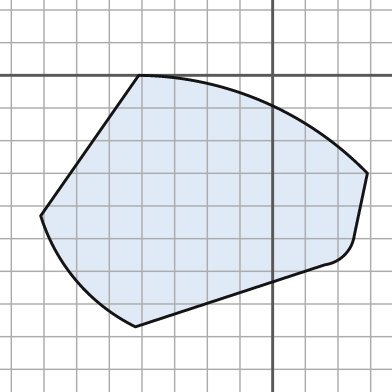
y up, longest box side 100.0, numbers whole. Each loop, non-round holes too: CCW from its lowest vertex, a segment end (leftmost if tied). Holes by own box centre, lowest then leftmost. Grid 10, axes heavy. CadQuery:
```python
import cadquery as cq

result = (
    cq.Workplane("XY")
    .moveTo(-42.0, -77.0)
    .lineTo(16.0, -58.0)
    .threePointArc((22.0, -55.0), (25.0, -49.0))
    .lineTo(29.0, -30.0)
    .threePointArc((-3.0, -8.0), (-41.0, 0.0))
    .lineTo(-71.0, -43.0)
    .threePointArc((-60.0, -63.0), (-42.0, -77.0))
    .close()
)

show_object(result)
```